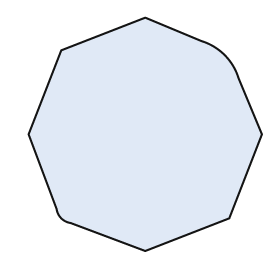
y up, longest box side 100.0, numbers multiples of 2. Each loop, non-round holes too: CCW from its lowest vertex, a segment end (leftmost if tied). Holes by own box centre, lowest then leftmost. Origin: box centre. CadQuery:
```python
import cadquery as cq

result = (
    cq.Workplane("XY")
    .moveTo(0.0, -50.0)
    .lineTo(36.0, -36.0)
    .lineTo(50.0, 0.0)
    .lineTo(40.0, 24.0)
    .threePointArc((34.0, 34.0), (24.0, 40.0))
    .lineTo(0.0, 50.0)
    .lineTo(-36.0, 36.0)
    .lineTo(-50.0, 0.0)
    .lineTo(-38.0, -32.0)
    .threePointArc((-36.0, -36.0), (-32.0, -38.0))
    .close()
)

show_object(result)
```